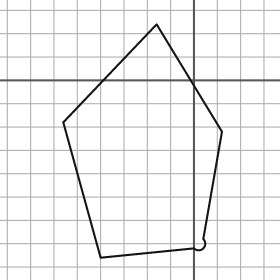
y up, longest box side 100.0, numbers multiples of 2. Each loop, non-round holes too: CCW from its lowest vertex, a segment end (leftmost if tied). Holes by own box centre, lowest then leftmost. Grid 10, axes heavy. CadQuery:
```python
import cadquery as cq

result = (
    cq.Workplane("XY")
    .moveTo(-40.0, -76.0)
    .lineTo(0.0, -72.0)
    .threePointArc((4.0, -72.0), (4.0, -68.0))
    .lineTo(12.0, -22.0)
    .lineTo(-16.0, 24.0)
    .lineTo(-56.0, -18.0)
    .close()
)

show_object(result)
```